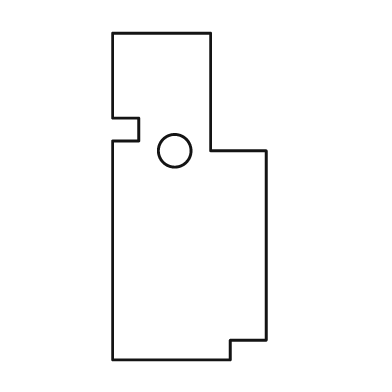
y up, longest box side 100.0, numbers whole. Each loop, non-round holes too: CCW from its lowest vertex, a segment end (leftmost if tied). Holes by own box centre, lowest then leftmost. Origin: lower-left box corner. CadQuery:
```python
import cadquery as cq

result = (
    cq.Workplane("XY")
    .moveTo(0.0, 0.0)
    .lineTo(36.0, 0.0)
    .lineTo(36.0, 6.0)
    .lineTo(47.0, 6.0)
    .lineTo(47.0, 64.0)
    .lineTo(30.0, 64.0)
    .lineTo(30.0, 100.0)
    .lineTo(0.0, 100.0)
    .lineTo(0.0, 74.0)
    .lineTo(8.0, 74.0)
    .lineTo(8.0, 67.0)
    .lineTo(0.0, 67.0)
    .close()
    .moveTo(19.0, 64.0)
    .circle(5.0)
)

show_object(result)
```